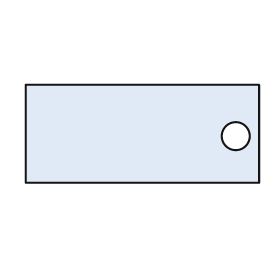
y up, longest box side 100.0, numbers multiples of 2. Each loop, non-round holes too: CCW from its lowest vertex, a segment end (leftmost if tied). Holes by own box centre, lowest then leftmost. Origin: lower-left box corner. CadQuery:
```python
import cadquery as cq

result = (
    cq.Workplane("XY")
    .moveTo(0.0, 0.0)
    .lineTo(100.0, 0.0)
    .lineTo(100.0, 42.0)
    .lineTo(0.0, 42.0)
    .close()
    .moveTo(90.0, 20.0)
    .circle(6.0)
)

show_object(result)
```